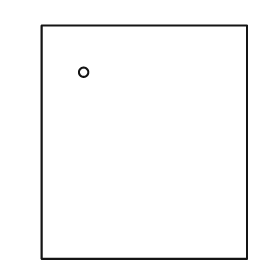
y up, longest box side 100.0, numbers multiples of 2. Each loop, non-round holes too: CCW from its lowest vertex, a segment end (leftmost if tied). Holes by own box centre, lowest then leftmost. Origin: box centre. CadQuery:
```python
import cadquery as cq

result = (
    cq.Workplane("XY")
    .moveTo(-44.0, -50.0)
    .lineTo(44.0, -50.0)
    .lineTo(44.0, 50.0)
    .lineTo(-44.0, 50.0)
    .close()
    .moveTo(-26.0, 30.0)
    .circle(2.0)
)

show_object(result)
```